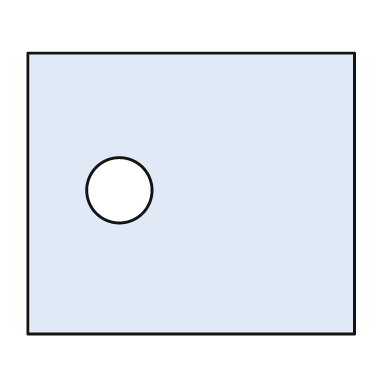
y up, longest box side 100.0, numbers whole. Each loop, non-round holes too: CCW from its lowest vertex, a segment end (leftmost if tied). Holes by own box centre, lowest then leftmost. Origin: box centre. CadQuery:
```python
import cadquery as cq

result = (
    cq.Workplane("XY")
    .moveTo(-50.0, -43.0)
    .lineTo(50.0, -43.0)
    .lineTo(50.0, 43.0)
    .lineTo(-50.0, 43.0)
    .close()
    .moveTo(-22.0, 1.0)
    .circle(10.0)
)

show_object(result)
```